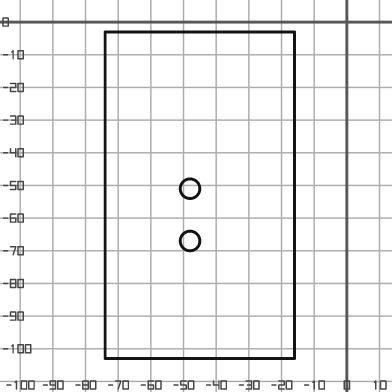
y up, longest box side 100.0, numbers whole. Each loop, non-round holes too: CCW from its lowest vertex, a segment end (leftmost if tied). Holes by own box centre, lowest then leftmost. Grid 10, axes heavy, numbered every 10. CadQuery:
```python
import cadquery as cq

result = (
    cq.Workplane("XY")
    .moveTo(-74.0, -103.0)
    .lineTo(-16.0, -103.0)
    .lineTo(-16.0, -3.0)
    .lineTo(-74.0, -3.0)
    .close()
    .moveTo(-48.0, -67.0)
    .circle(3.0)
    .moveTo(-48.0, -51.0)
    .circle(3.0)
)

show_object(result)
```